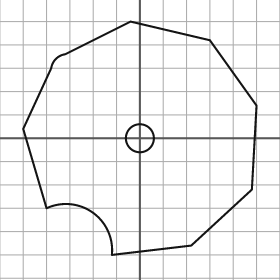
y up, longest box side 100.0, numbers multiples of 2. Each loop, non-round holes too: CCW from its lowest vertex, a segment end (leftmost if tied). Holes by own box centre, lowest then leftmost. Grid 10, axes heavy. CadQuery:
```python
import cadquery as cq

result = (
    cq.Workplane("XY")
    .moveTo(-12.0, -50.0)
    .lineTo(22.0, -46.0)
    .lineTo(48.0, -22.0)
    .lineTo(50.0, 14.0)
    .lineTo(30.0, 42.0)
    .lineTo(-4.0, 50.0)
    .lineTo(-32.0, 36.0)
    .threePointArc((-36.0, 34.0), (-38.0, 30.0))
    .lineTo(-50.0, 4.0)
    .lineTo(-40.0, -30.0)
    .threePointArc((-20.0, -32.0), (-12.0, -50.0))
    .close()
    .moveTo(0.0, 0.0)
    .circle(6.0)
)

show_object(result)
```